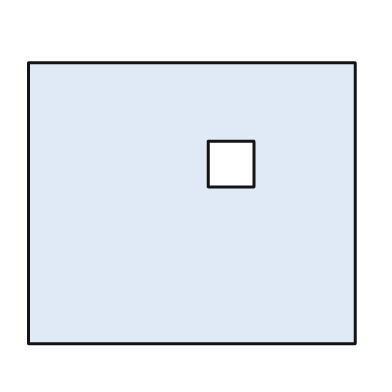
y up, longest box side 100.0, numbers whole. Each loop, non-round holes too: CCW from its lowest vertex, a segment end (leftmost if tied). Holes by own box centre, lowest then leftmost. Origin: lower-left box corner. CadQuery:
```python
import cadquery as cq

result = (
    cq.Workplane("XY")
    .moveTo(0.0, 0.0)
    .lineTo(100.0, 0.0)
    .lineTo(100.0, 86.0)
    .lineTo(0.0, 86.0)
    .close()
    .moveTo(55.0, 48.0)
    .lineTo(69.0, 48.0)
    .lineTo(69.0, 62.0)
    .lineTo(55.0, 62.0)
    .close()
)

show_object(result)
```